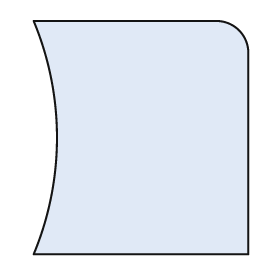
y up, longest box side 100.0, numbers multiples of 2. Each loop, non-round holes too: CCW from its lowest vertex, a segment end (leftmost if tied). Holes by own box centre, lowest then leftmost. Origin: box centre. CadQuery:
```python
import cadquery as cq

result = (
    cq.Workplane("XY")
    .moveTo(-46.0, -50.0)
    .lineTo(46.0, -50.0)
    .lineTo(46.0, 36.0)
    .threePointArc((42.0, 46.0), (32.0, 50.0))
    .lineTo(-46.0, 50.0)
    .threePointArc((-36.0, 0.0), (-46.0, -50.0))
    .close()
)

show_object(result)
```